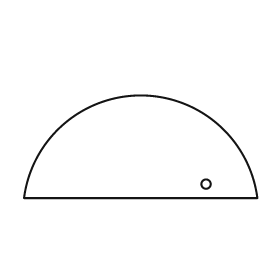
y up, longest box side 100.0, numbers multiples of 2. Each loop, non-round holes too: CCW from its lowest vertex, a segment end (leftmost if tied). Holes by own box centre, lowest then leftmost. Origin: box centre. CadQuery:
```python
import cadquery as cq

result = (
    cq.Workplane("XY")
    .moveTo(-50.0, -22.0)
    .lineTo(50.0, -22.0)
    .threePointArc((0.0, 22.0), (-50.0, -22.0))
    .close()
    .moveTo(28.0, -16.0)
    .circle(2.0)
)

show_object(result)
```